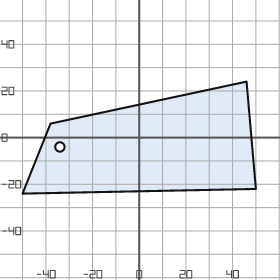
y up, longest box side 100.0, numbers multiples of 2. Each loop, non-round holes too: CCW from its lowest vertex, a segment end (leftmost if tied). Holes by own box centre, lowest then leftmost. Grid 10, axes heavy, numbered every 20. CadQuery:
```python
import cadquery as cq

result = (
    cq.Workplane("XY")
    .moveTo(-50.0, -24.0)
    .lineTo(50.0, -22.0)
    .lineTo(46.0, 24.0)
    .lineTo(-38.0, 6.0)
    .close()
    .moveTo(-34.0, -4.0)
    .circle(2.0)
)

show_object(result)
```